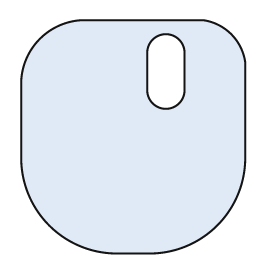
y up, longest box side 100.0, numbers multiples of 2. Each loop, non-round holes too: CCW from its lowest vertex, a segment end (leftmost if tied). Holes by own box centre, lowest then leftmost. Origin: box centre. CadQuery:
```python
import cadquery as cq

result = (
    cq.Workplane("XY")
    .moveTo(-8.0, -50.0)
    .lineTo(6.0, -50.0)
    .threePointArc((36.0, -38.0), (48.0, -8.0))
    .lineTo(48.0, 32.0)
    .threePointArc((42.0, 44.0), (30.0, 50.0))
    .lineTo(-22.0, 50.0)
    .threePointArc((-40.0, 42.0), (-48.0, 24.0))
    .lineTo(-48.0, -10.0)
    .threePointArc((-36.0, -38.0), (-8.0, -50.0))
    .close()
    .moveTo(6.0, 20.0)
    .threePointArc((14.0, 12.0), (22.0, 20.0))
    .lineTo(22.0, 36.0)
    .threePointArc((14.0, 44.0), (6.0, 36.0))
    .close()
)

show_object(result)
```